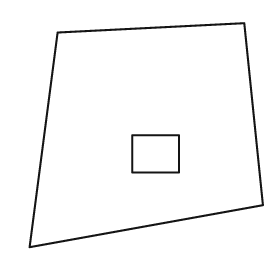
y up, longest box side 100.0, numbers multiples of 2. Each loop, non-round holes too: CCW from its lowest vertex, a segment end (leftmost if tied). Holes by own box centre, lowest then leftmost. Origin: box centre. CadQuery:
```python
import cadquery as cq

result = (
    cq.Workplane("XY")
    .moveTo(-50.0, -48.0)
    .lineTo(50.0, -30.0)
    .lineTo(42.0, 48.0)
    .lineTo(-38.0, 44.0)
    .close()
    .moveTo(-6.0, -16.0)
    .lineTo(14.0, -16.0)
    .lineTo(14.0, 0.0)
    .lineTo(-6.0, 0.0)
    .close()
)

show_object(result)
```